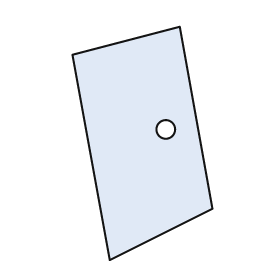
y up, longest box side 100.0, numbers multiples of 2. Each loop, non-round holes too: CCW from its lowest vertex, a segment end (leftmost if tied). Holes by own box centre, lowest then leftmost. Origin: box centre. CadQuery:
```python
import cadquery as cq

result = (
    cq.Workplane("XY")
    .moveTo(-14.0, -50.0)
    .lineTo(30.0, -28.0)
    .lineTo(16.0, 50.0)
    .lineTo(-30.0, 38.0)
    .close()
    .moveTo(10.0, 6.0)
    .circle(4.0)
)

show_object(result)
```